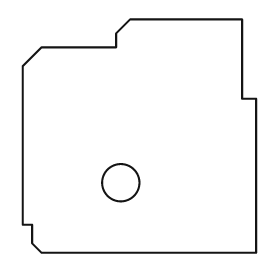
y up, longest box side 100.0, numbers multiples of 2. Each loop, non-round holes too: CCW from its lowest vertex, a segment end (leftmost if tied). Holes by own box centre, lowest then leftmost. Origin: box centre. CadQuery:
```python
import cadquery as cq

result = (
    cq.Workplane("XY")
    .moveTo(-42.0, -50.0)
    .lineTo(50.0, -50.0)
    .lineTo(50.0, 16.0)
    .lineTo(44.0, 16.0)
    .lineTo(44.0, 50.0)
    .lineTo(-4.0, 50.0)
    .lineTo(-10.0, 44.0)
    .lineTo(-10.0, 38.0)
    .lineTo(-42.0, 38.0)
    .lineTo(-50.0, 30.0)
    .lineTo(-50.0, -38.0)
    .lineTo(-46.0, -38.0)
    .lineTo(-46.0, -46.0)
    .close()
    .moveTo(-8.0, -20.0)
    .circle(8.0)
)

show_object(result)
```